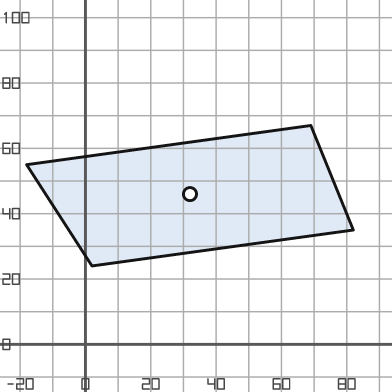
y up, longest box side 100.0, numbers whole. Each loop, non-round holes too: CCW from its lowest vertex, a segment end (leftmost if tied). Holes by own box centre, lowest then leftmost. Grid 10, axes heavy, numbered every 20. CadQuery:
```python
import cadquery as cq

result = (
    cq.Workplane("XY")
    .moveTo(2.0, 24.0)
    .lineTo(82.0, 35.0)
    .lineTo(69.0, 67.0)
    .lineTo(-18.0, 55.0)
    .close()
    .moveTo(32.0, 46.0)
    .circle(2.0)
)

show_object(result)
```